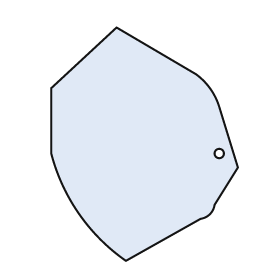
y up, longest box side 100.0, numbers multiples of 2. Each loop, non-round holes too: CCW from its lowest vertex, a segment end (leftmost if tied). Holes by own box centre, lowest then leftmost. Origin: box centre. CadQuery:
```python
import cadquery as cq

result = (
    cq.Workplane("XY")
    .moveTo(-8.0, -50.0)
    .lineTo(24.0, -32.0)
    .threePointArc((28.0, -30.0), (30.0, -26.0))
    .lineTo(40.0, -10.0)
    .lineTo(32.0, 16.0)
    .threePointArc((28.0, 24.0), (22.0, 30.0))
    .lineTo(-12.0, 50.0)
    .lineTo(-40.0, 24.0)
    .lineTo(-40.0, -4.0)
    .threePointArc((-28.0, -30.0), (-8.0, -50.0))
    .close()
    .moveTo(32.0, -4.0)
    .circle(2.0)
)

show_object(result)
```